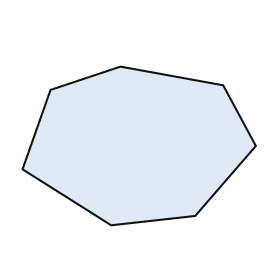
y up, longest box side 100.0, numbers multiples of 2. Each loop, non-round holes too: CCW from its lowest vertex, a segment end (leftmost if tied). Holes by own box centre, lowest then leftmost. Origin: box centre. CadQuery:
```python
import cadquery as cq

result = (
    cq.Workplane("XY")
    .moveTo(-12.0, -34.0)
    .lineTo(24.0, -30.0)
    .lineTo(50.0, 0.0)
    .lineTo(36.0, 26.0)
    .lineTo(-8.0, 34.0)
    .lineTo(-38.0, 24.0)
    .lineTo(-50.0, -10.0)
    .close()
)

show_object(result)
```